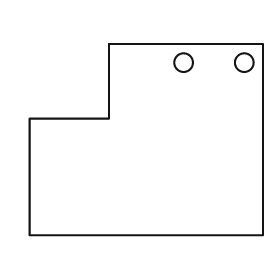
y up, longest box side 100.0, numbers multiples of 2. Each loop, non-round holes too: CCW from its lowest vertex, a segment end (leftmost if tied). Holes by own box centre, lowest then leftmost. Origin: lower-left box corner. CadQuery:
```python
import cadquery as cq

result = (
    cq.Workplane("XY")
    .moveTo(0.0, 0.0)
    .lineTo(100.0, 0.0)
    .lineTo(100.0, 82.0)
    .lineTo(34.0, 82.0)
    .lineTo(34.0, 50.0)
    .lineTo(0.0, 50.0)
    .close()
    .moveTo(66.0, 74.0)
    .circle(4.0)
    .moveTo(92.0, 74.0)
    .circle(4.0)
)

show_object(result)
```